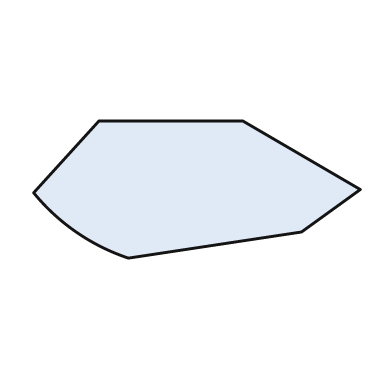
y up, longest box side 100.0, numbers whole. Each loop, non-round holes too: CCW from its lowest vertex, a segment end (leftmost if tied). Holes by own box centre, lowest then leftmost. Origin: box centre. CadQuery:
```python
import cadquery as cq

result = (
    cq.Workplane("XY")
    .moveTo(-21.0, -21.0)
    .lineTo(32.0, -13.0)
    .lineTo(50.0, 0.0)
    .lineTo(14.0, 21.0)
    .lineTo(-30.0, 21.0)
    .lineTo(-50.0, -1.0)
    .threePointArc((-37.0, -13.0), (-21.0, -21.0))
    .close()
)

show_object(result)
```